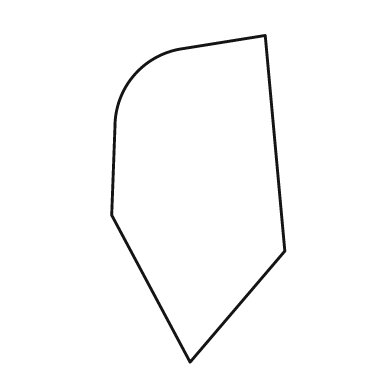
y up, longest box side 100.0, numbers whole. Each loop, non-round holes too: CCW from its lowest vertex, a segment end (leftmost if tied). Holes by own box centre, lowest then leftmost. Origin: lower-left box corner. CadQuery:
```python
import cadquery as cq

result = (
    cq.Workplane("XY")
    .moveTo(24.0, 0.0)
    .lineTo(53.0, 34.0)
    .lineTo(47.0, 100.0)
    .lineTo(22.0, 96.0)
    .threePointArc((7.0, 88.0), (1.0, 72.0))
    .lineTo(0.0, 45.0)
    .close()
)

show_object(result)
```